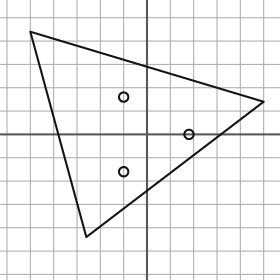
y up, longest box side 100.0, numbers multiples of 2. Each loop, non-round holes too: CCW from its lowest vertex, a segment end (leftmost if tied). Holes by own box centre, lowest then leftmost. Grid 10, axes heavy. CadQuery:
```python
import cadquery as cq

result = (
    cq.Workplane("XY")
    .moveTo(-26.0, -44.0)
    .lineTo(50.0, 14.0)
    .lineTo(-50.0, 44.0)
    .close()
    .moveTo(-10.0, -16.0)
    .circle(2.0)
    .moveTo(18.0, 0.0)
    .circle(2.0)
    .moveTo(-10.0, 16.0)
    .circle(2.0)
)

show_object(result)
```